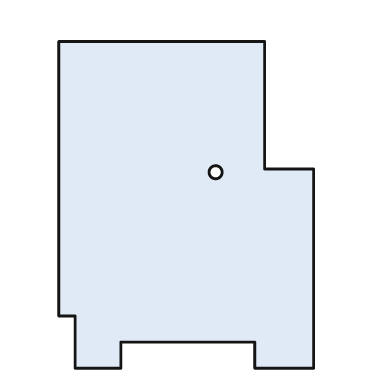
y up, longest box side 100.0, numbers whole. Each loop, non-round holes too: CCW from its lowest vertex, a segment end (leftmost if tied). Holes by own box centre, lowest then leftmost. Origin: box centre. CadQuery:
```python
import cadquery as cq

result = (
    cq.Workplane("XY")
    .moveTo(-34.0, -50.0)
    .lineTo(-20.0, -50.0)
    .lineTo(-20.0, -42.0)
    .lineTo(21.0, -42.0)
    .lineTo(21.0, -50.0)
    .lineTo(39.0, -50.0)
    .lineTo(39.0, 11.0)
    .lineTo(24.0, 11.0)
    .lineTo(24.0, 50.0)
    .lineTo(-39.0, 50.0)
    .lineTo(-39.0, -34.0)
    .lineTo(-34.0, -34.0)
    .close()
    .moveTo(9.0, 10.0)
    .circle(2.0)
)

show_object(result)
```